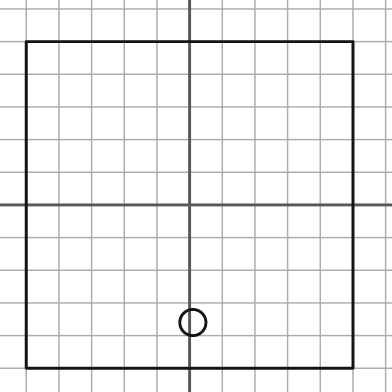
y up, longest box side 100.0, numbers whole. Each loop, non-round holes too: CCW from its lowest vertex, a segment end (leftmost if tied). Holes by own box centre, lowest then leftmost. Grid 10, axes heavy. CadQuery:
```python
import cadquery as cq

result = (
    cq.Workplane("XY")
    .moveTo(-50.0, -50.0)
    .lineTo(50.0, -50.0)
    .lineTo(50.0, 50.0)
    .lineTo(-50.0, 50.0)
    .close()
    .moveTo(1.0, -36.0)
    .circle(4.0)
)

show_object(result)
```